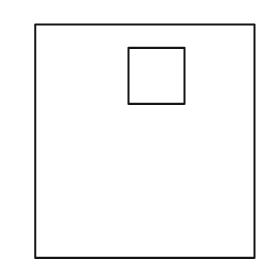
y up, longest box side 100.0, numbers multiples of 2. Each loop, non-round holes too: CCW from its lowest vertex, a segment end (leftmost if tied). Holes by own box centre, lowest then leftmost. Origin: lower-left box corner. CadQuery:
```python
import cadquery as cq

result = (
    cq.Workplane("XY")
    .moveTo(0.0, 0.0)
    .lineTo(94.0, 0.0)
    .lineTo(94.0, 100.0)
    .lineTo(0.0, 100.0)
    .close()
    .moveTo(40.0, 66.0)
    .lineTo(64.0, 66.0)
    .lineTo(64.0, 90.0)
    .lineTo(40.0, 90.0)
    .close()
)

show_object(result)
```